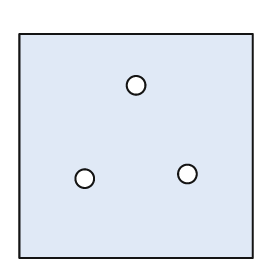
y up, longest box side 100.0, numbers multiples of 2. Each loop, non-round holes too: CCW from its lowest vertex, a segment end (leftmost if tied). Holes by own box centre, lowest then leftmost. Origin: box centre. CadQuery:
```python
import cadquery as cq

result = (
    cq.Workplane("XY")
    .moveTo(-50.0, -48.0)
    .lineTo(50.0, -48.0)
    .lineTo(50.0, 48.0)
    .lineTo(-50.0, 48.0)
    .close()
    .moveTo(-22.0, -14.0)
    .circle(4.0)
    .moveTo(22.0, -12.0)
    .circle(4.0)
    .moveTo(0.0, 26.0)
    .circle(4.0)
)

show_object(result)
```